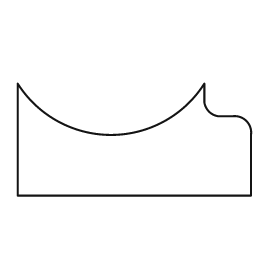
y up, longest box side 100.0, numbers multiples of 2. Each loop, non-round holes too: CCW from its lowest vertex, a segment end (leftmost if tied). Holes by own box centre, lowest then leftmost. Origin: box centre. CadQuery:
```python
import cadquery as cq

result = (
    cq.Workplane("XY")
    .moveTo(-50.0, -24.0)
    .lineTo(50.0, -24.0)
    .lineTo(50.0, 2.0)
    .threePointArc((48.0, 8.0), (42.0, 10.0))
    .lineTo(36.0, 10.0)
    .threePointArc((32.0, 12.0), (30.0, 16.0))
    .lineTo(30.0, 24.0)
    .threePointArc((-10.0, 2.0), (-50.0, 24.0))
    .close()
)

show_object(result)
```